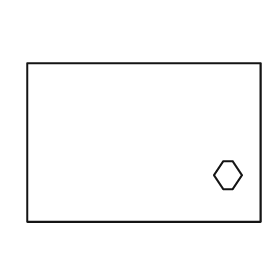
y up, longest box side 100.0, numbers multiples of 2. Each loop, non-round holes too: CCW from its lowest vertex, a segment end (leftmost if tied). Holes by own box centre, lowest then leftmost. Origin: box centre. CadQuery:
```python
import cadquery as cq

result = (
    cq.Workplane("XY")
    .moveTo(-50.0, -34.0)
    .lineTo(50.0, -34.0)
    .lineTo(50.0, 34.0)
    .lineTo(-50.0, 34.0)
    .close()
    .moveTo(34.0, -20.0)
    .lineTo(38.0, -20.0)
    .lineTo(42.0, -14.0)
    .lineTo(38.0, -8.0)
    .lineTo(34.0, -8.0)
    .lineTo(30.0, -14.0)
    .close()
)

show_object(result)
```